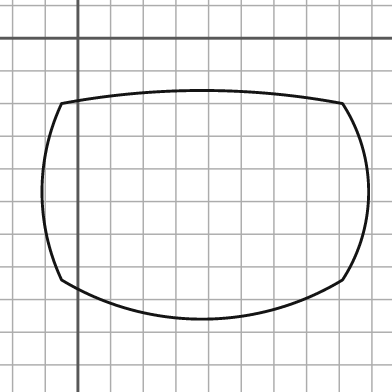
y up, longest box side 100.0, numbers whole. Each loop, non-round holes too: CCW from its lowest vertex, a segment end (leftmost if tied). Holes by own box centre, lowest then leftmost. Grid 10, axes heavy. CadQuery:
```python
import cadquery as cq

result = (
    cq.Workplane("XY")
    .moveTo(-5.0, -74.0)
    .threePointArc((38.0, -86.0), (81.0, -74.0))
    .threePointArc((89.0, -47.0), (81.0, -20.0))
    .threePointArc((38.0, -16.0), (-5.0, -20.0))
    .threePointArc((-11.0, -47.0), (-5.0, -74.0))
    .close()
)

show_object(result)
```